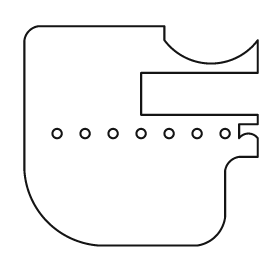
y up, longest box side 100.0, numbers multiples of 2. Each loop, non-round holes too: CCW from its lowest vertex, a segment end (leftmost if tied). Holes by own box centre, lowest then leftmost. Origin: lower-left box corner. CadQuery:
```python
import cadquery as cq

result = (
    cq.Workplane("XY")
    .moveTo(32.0, 0.0)
    .lineTo(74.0, 0.0)
    .threePointArc((82.0, 4.0), (86.0, 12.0))
    .lineTo(86.0, 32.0)
    .threePointArc((88.0, 36.0), (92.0, 38.0))
    .lineTo(100.0, 38.0)
    .lineTo(100.0, 46.0)
    .threePointArc((96.0, 48.0), (92.0, 46.0))
    .lineTo(92.0, 52.0)
    .lineTo(100.0, 52.0)
    .lineTo(100.0, 56.0)
    .lineTo(50.0, 56.0)
    .lineTo(50.0, 74.0)
    .lineTo(100.0, 74.0)
    .lineTo(100.0, 88.0)
    .threePointArc((80.0, 78.0), (60.0, 88.0))
    .lineTo(60.0, 94.0)
    .lineTo(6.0, 94.0)
    .threePointArc((2.0, 92.0), (0.0, 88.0))
    .lineTo(0.0, 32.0)
    .threePointArc((10.0, 10.0), (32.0, 0.0))
    .close()
    .moveTo(14.0, 48.0)
    .circle(2.0)
    .moveTo(26.0, 48.0)
    .circle(2.0)
    .moveTo(38.0, 48.0)
    .circle(2.0)
    .moveTo(50.0, 48.0)
    .circle(2.0)
    .moveTo(62.0, 48.0)
    .circle(2.0)
    .moveTo(74.0, 48.0)
    .circle(2.0)
    .moveTo(86.0, 48.0)
    .circle(2.0)
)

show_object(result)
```